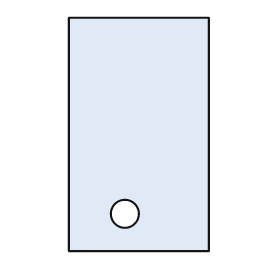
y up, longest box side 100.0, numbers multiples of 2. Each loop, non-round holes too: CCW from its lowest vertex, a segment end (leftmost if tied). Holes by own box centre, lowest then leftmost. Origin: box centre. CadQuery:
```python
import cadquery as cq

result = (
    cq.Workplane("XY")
    .moveTo(-30.0, -50.0)
    .lineTo(30.0, -50.0)
    .lineTo(30.0, 50.0)
    .lineTo(-30.0, 50.0)
    .close()
    .moveTo(-6.0, -34.0)
    .circle(6.0)
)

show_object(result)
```